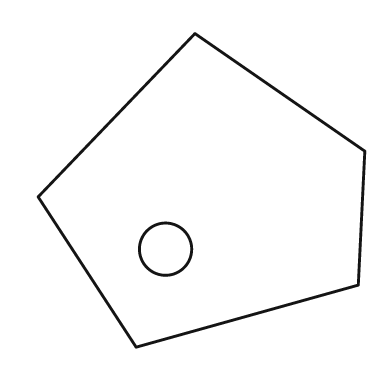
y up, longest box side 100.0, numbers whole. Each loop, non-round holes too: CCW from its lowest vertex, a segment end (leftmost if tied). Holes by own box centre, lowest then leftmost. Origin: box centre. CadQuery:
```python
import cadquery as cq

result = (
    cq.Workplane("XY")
    .moveTo(-20.0, -48.0)
    .lineTo(48.0, -29.0)
    .lineTo(50.0, 12.0)
    .lineTo(-2.0, 48.0)
    .lineTo(-50.0, -2.0)
    .close()
    .moveTo(-11.0, -18.0)
    .circle(8.0)
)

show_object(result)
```